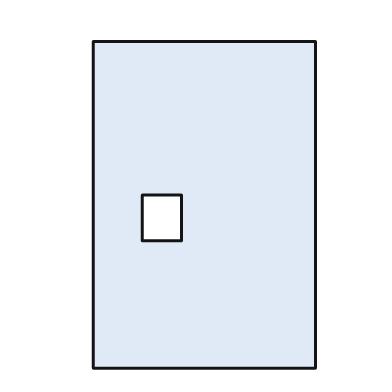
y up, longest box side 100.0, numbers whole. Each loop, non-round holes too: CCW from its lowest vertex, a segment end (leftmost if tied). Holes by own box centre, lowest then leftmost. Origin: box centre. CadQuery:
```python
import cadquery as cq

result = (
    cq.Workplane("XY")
    .moveTo(-34.0, -50.0)
    .lineTo(34.0, -50.0)
    .lineTo(34.0, 50.0)
    .lineTo(-34.0, 50.0)
    .close()
    .moveTo(-19.0, -11.0)
    .lineTo(-7.0, -11.0)
    .lineTo(-7.0, 3.0)
    .lineTo(-19.0, 3.0)
    .close()
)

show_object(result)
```